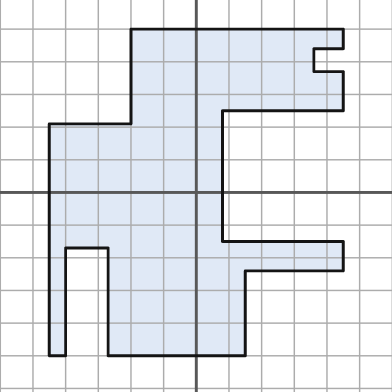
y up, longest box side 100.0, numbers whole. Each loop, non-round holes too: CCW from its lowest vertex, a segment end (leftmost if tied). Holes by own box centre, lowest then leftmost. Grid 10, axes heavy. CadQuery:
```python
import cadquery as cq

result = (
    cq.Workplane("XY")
    .moveTo(-45.0, -50.0)
    .lineTo(-40.0, -50.0)
    .lineTo(-40.0, -17.0)
    .lineTo(-27.0, -17.0)
    .lineTo(-27.0, -50.0)
    .lineTo(15.0, -50.0)
    .lineTo(15.0, -24.0)
    .lineTo(45.0, -24.0)
    .lineTo(45.0, -15.0)
    .lineTo(8.0, -15.0)
    .lineTo(8.0, 25.0)
    .lineTo(45.0, 25.0)
    .lineTo(45.0, 37.0)
    .lineTo(36.0, 37.0)
    .lineTo(36.0, 44.0)
    .lineTo(45.0, 44.0)
    .lineTo(45.0, 50.0)
    .lineTo(-20.0, 50.0)
    .lineTo(-20.0, 21.0)
    .lineTo(-45.0, 21.0)
    .close()
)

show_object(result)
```